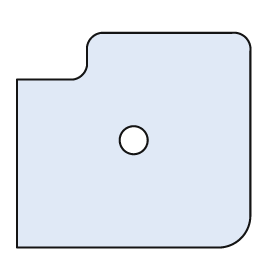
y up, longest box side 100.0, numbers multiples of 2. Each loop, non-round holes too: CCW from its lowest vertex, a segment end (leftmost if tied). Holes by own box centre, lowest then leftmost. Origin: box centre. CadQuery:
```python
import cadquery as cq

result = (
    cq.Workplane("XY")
    .moveTo(-50.0, -46.0)
    .lineTo(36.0, -46.0)
    .threePointArc((46.0, -42.0), (50.0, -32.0))
    .lineTo(50.0, 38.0)
    .threePointArc((48.0, 44.0), (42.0, 46.0))
    .lineTo(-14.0, 46.0)
    .threePointArc((-18.0, 44.0), (-20.0, 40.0))
    .lineTo(-20.0, 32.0)
    .threePointArc((-22.0, 28.0), (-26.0, 26.0))
    .lineTo(-50.0, 26.0)
    .close()
    .moveTo(0.0, 0.0)
    .circle(6.0)
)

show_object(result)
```